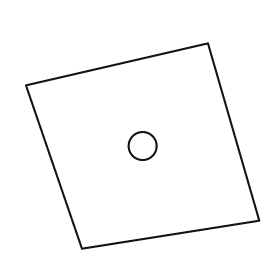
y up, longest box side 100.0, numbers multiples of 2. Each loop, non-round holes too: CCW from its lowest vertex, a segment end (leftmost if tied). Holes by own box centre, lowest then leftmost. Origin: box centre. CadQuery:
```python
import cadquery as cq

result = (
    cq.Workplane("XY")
    .moveTo(-26.0, -44.0)
    .lineTo(50.0, -32.0)
    .lineTo(28.0, 44.0)
    .lineTo(-50.0, 26.0)
    .close()
    .moveTo(0.0, 0.0)
    .circle(6.0)
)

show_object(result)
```